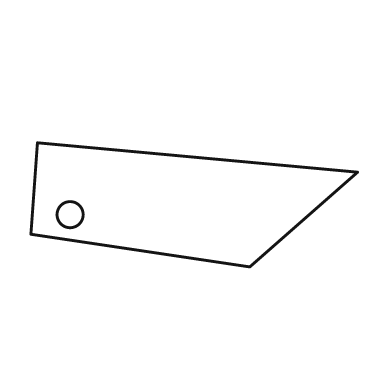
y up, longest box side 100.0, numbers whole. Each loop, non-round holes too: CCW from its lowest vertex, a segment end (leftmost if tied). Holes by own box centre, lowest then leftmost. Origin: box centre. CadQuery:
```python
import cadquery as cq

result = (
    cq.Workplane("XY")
    .moveTo(17.0, -19.0)
    .lineTo(50.0, 10.0)
    .lineTo(-48.0, 19.0)
    .lineTo(-50.0, -9.0)
    .close()
    .moveTo(-38.0, -3.0)
    .circle(4.0)
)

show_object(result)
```